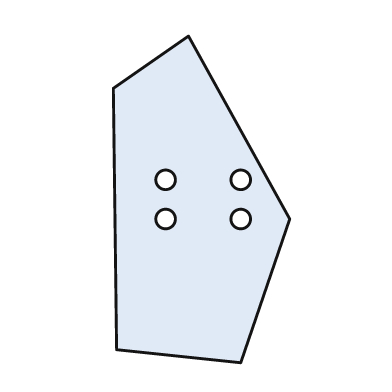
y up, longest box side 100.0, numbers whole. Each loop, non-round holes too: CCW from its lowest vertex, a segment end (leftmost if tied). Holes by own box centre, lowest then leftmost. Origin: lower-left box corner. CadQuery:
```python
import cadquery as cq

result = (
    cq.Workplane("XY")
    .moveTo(39.0, 0.0)
    .lineTo(54.0, 44.0)
    .lineTo(23.0, 100.0)
    .lineTo(0.0, 84.0)
    .lineTo(1.0, 4.0)
    .close()
    .moveTo(16.0, 44.0)
    .circle(3.0)
    .moveTo(39.0, 44.0)
    .circle(3.0)
    .moveTo(16.0, 56.0)
    .circle(3.0)
    .moveTo(39.0, 56.0)
    .circle(3.0)
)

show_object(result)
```